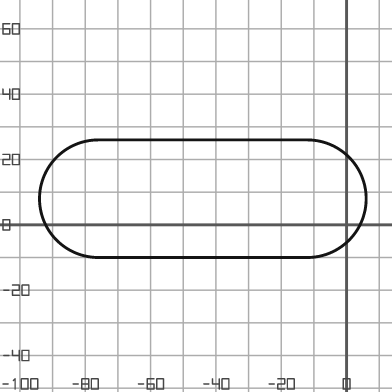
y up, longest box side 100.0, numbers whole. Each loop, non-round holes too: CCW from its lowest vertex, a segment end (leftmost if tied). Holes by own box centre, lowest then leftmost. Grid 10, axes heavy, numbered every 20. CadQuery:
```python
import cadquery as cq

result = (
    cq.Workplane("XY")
    .moveTo(-76.0, -10.0)
    .lineTo(-12.0, -10.0)
    .threePointArc((6.0, 8.0), (-12.0, 26.0))
    .lineTo(-76.0, 26.0)
    .threePointArc((-94.0, 8.0), (-76.0, -10.0))
    .close()
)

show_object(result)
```